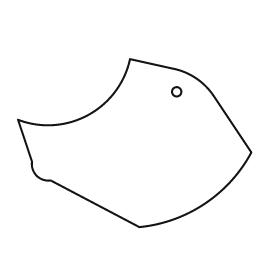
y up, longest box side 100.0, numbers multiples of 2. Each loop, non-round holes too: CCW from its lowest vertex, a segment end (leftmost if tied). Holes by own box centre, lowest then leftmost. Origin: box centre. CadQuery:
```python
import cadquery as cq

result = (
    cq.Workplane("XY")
    .moveTo(2.0, -36.0)
    .threePointArc((30.0, -26.0), (50.0, -4.0))
    .lineTo(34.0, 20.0)
    .threePointArc((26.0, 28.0), (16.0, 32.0))
    .lineTo(-2.0, 36.0)
    .threePointArc((-20.0, 12.0), (-50.0, 10.0))
    .lineTo(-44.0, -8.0)
    .threePointArc((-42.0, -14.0), (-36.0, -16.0))
    .close()
    .moveTo(18.0, 22.0)
    .circle(2.0)
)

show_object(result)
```